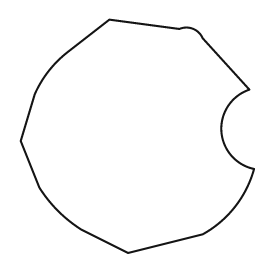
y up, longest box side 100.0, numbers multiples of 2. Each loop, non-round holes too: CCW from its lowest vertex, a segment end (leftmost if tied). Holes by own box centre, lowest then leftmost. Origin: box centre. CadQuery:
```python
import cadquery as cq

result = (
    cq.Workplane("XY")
    .moveTo(-4.0, -50.0)
    .lineTo(28.0, -42.0)
    .threePointArc((42.0, -30.0), (50.0, -14.0))
    .threePointArc((36.0, 2.0), (48.0, 20.0))
    .lineTo(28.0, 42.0)
    .threePointArc((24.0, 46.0), (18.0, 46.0))
    .lineTo(-12.0, 50.0)
    .lineTo(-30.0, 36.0)
    .threePointArc((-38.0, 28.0), (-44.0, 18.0))
    .lineTo(-50.0, -2.0)
    .lineTo(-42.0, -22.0)
    .threePointArc((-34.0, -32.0), (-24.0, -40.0))
    .close()
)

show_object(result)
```